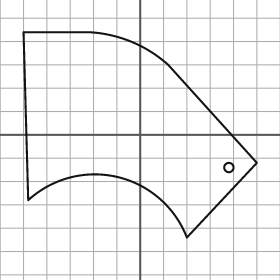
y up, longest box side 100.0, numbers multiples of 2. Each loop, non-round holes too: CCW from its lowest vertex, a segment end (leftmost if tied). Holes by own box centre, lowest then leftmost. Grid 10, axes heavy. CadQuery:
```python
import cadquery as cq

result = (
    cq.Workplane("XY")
    .moveTo(20.0, -44.0)
    .lineTo(50.0, -12.0)
    .lineTo(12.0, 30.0)
    .threePointArc((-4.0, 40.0), (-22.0, 44.0))
    .lineTo(-50.0, 44.0)
    .lineTo(-48.0, -28.0)
    .threePointArc((-10.0, -18.0), (20.0, -44.0))
    .close()
    .moveTo(38.0, -14.0)
    .circle(2.0)
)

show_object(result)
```